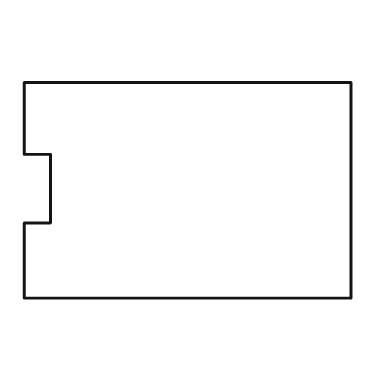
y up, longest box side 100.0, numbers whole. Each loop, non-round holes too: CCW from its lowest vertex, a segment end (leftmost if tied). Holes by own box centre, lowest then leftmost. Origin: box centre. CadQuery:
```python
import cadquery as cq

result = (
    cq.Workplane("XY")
    .moveTo(-50.0, -33.0)
    .lineTo(50.0, -33.0)
    .lineTo(50.0, 33.0)
    .lineTo(-50.0, 33.0)
    .lineTo(-50.0, 11.0)
    .lineTo(-42.0, 11.0)
    .lineTo(-42.0, -10.0)
    .lineTo(-50.0, -10.0)
    .close()
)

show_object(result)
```